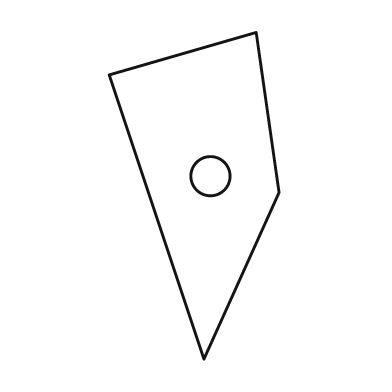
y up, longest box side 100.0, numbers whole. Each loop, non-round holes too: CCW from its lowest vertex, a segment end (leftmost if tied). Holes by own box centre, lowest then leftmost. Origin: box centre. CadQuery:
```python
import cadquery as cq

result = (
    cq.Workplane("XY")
    .moveTo(3.0, -50.0)
    .lineTo(26.0, 1.0)
    .lineTo(19.0, 50.0)
    .lineTo(-26.0, 37.0)
    .close()
    .moveTo(5.0, 6.0)
    .circle(6.0)
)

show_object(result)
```